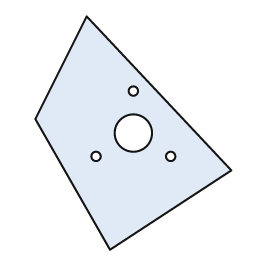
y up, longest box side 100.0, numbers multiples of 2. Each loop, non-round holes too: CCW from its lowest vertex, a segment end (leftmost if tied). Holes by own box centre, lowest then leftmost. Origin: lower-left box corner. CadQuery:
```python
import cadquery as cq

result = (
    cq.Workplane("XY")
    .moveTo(32.0, 0.0)
    .lineTo(84.0, 34.0)
    .lineTo(22.0, 100.0)
    .lineTo(0.0, 56.0)
    .close()
    .moveTo(26.0, 40.0)
    .circle(2.0)
    .moveTo(58.0, 40.0)
    .circle(2.0)
    .moveTo(42.0, 50.0)
    .circle(8.0)
    .moveTo(42.0, 68.0)
    .circle(2.0)
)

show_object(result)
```